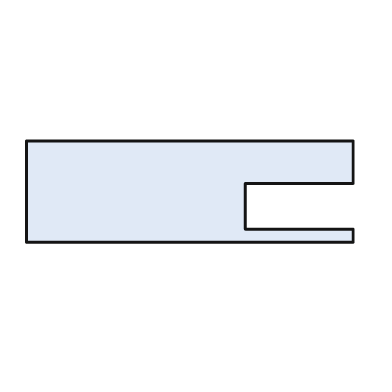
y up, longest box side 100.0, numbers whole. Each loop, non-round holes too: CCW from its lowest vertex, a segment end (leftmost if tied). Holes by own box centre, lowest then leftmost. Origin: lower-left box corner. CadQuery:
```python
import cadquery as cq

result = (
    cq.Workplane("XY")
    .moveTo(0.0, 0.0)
    .lineTo(100.0, 0.0)
    .lineTo(100.0, 4.0)
    .lineTo(67.0, 4.0)
    .lineTo(67.0, 18.0)
    .lineTo(100.0, 18.0)
    .lineTo(100.0, 31.0)
    .lineTo(0.0, 31.0)
    .close()
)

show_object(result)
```